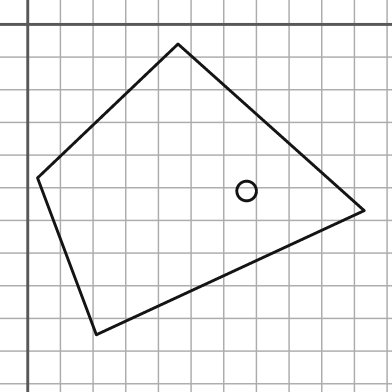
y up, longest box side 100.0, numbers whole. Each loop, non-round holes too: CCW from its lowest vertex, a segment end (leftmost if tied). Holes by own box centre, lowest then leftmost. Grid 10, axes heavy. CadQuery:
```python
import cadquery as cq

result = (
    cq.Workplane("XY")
    .moveTo(21.0, -95.0)
    .lineTo(103.0, -57.0)
    .lineTo(46.0, -6.0)
    .lineTo(3.0, -47.0)
    .close()
    .moveTo(67.0, -51.0)
    .circle(3.0)
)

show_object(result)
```